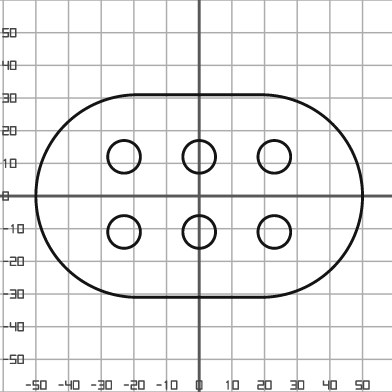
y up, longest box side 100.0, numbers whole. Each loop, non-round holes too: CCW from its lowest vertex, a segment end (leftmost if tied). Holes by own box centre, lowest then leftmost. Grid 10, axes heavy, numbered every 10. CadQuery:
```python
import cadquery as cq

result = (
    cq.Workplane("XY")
    .moveTo(-19.0, -31.0)
    .lineTo(19.0, -31.0)
    .threePointArc((50.0, 0.0), (19.0, 31.0))
    .lineTo(-19.0, 31.0)
    .threePointArc((-50.0, 0.0), (-19.0, -31.0))
    .close()
    .moveTo(-23.0, -11.0)
    .circle(5.0)
    .moveTo(0.0, -11.0)
    .circle(5.0)
    .moveTo(23.0, -11.0)
    .circle(5.0)
    .moveTo(-23.0, 12.0)
    .circle(5.0)
    .moveTo(0.0, 12.0)
    .circle(5.0)
    .moveTo(23.0, 12.0)
    .circle(5.0)
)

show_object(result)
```